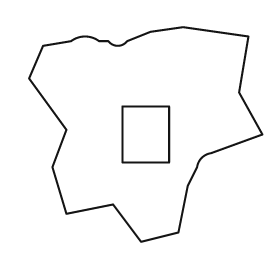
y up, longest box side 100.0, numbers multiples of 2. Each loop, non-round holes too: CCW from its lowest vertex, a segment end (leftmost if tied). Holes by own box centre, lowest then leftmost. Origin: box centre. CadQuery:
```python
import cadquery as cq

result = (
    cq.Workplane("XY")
    .moveTo(-2.0, -46.0)
    .lineTo(14.0, -42.0)
    .lineTo(18.0, -22.0)
    .lineTo(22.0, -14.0)
    .threePointArc((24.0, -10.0), (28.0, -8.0))
    .lineTo(50.0, 0.0)
    .lineTo(40.0, 18.0)
    .lineTo(44.0, 42.0)
    .lineTo(16.0, 46.0)
    .lineTo(2.0, 44.0)
    .lineTo(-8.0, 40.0)
    .threePointArc((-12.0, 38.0), (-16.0, 40.0))
    .lineTo(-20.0, 40.0)
    .threePointArc((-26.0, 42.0), (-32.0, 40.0))
    .lineTo(-44.0, 38.0)
    .lineTo(-50.0, 24.0)
    .lineTo(-34.0, 2.0)
    .lineTo(-40.0, -14.0)
    .lineTo(-34.0, -34.0)
    .lineTo(-14.0, -30.0)
    .close()
    .moveTo(-10.0, -12.0)
    .lineTo(10.0, -12.0)
    .lineTo(10.0, 12.0)
    .lineTo(-10.0, 12.0)
    .close()
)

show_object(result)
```